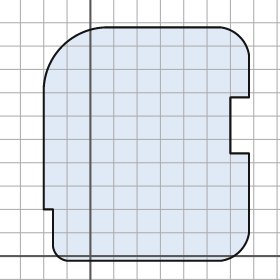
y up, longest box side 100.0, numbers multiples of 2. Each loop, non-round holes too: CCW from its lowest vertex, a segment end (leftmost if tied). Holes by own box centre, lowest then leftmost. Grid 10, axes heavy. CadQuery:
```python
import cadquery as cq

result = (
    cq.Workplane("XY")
    .moveTo(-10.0, -2.0)
    .lineTo(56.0, -2.0)
    .threePointArc((64.0, 2.0), (68.0, 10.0))
    .lineTo(68.0, 44.0)
    .lineTo(60.0, 44.0)
    .lineTo(60.0, 68.0)
    .lineTo(68.0, 68.0)
    .lineTo(68.0, 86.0)
    .threePointArc((64.0, 94.0), (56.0, 98.0))
    .lineTo(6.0, 98.0)
    .threePointArc((-12.0, 90.0), (-20.0, 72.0))
    .lineTo(-20.0, 20.0)
    .lineTo(-16.0, 20.0)
    .lineTo(-16.0, 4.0)
    .threePointArc((-14.0, 0.0), (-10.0, -2.0))
    .close()
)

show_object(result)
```